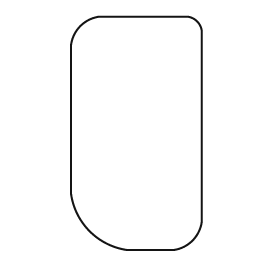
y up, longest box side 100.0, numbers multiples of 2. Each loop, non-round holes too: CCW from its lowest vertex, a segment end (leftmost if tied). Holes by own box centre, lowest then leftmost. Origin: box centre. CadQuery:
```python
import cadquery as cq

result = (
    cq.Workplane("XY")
    .moveTo(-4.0, -50.0)
    .lineTo(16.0, -50.0)
    .threePointArc((24.0, -46.0), (28.0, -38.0))
    .lineTo(28.0, 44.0)
    .threePointArc((26.0, 48.0), (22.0, 50.0))
    .lineTo(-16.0, 50.0)
    .threePointArc((-24.0, 46.0), (-28.0, 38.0))
    .lineTo(-28.0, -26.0)
    .threePointArc((-20.0, -42.0), (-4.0, -50.0))
    .close()
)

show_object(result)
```